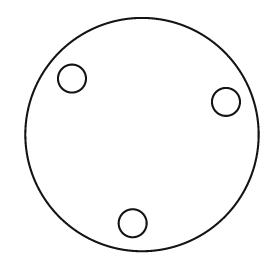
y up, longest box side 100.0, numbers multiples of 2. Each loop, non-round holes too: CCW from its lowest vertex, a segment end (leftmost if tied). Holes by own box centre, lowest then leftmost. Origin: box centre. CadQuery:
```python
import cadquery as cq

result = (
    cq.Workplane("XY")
    .moveTo(0.0, 0.0)
    .circle(50.0)
    .moveTo(-4.0, -38.0)
    .circle(6.0)
    .moveTo(36.0, 14.0)
    .circle(6.0)
    .moveTo(-30.0, 24.0)
    .circle(6.0)
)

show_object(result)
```